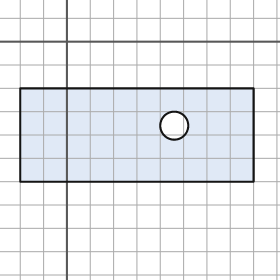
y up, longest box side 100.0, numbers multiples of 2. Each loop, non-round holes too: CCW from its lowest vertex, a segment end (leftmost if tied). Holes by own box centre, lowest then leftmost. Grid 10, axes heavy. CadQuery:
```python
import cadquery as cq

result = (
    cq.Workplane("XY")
    .moveTo(-20.0, -60.0)
    .lineTo(80.0, -60.0)
    .lineTo(80.0, -20.0)
    .lineTo(-20.0, -20.0)
    .close()
    .moveTo(46.0, -36.0)
    .circle(6.0)
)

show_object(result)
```